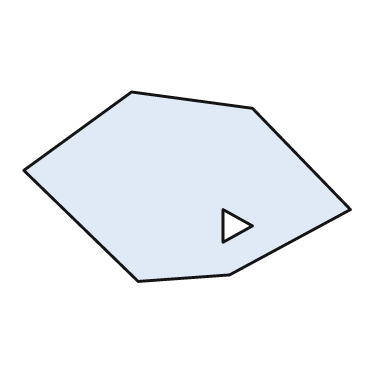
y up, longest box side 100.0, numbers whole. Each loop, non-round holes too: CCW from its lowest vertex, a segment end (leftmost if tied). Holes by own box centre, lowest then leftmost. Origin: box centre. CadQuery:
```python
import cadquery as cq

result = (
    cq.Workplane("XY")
    .moveTo(-15.0, -29.0)
    .lineTo(13.0, -27.0)
    .lineTo(50.0, -7.0)
    .lineTo(20.0, 24.0)
    .lineTo(-17.0, 29.0)
    .lineTo(-50.0, 5.0)
    .close()
    .moveTo(11.0, -17.0)
    .lineTo(20.0, -12.0)
    .lineTo(11.0, -7.0)
    .close()
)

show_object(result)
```